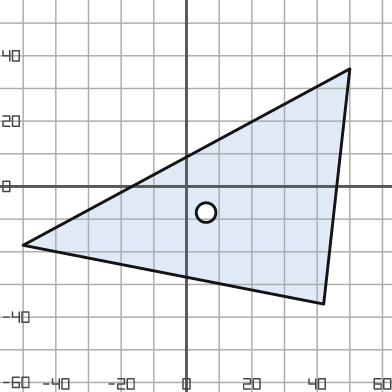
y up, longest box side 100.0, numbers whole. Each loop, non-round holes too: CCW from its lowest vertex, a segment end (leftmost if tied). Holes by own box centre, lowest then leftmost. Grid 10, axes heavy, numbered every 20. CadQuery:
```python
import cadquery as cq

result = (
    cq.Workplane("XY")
    .moveTo(42.0, -36.0)
    .lineTo(50.0, 36.0)
    .lineTo(-50.0, -18.0)
    .close()
    .moveTo(6.0, -8.0)
    .circle(3.0)
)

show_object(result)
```